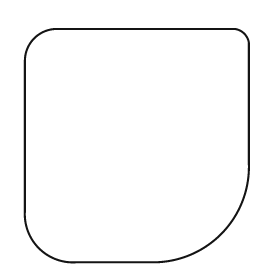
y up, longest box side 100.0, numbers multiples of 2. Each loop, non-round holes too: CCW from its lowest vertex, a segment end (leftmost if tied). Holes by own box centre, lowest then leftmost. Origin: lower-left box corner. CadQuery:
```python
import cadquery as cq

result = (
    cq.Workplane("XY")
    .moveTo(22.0, 0.0)
    .lineTo(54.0, 0.0)
    .threePointArc((84.0, 12.0), (96.0, 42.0))
    .lineTo(96.0, 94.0)
    .threePointArc((94.0, 98.0), (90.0, 100.0))
    .lineTo(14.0, 100.0)
    .threePointArc((4.0, 96.0), (0.0, 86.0))
    .lineTo(0.0, 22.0)
    .threePointArc((6.0, 6.0), (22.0, 0.0))
    .close()
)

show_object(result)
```